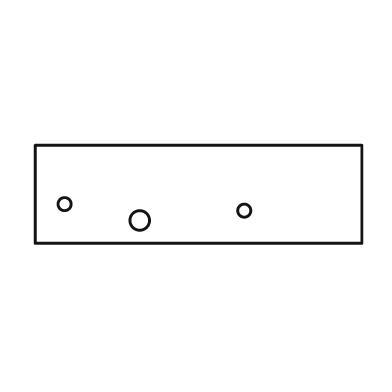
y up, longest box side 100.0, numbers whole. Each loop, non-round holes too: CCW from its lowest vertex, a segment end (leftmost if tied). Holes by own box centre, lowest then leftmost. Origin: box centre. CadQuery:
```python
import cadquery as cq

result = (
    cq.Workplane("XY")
    .moveTo(-50.0, -15.0)
    .lineTo(50.0, -15.0)
    .lineTo(50.0, 15.0)
    .lineTo(-50.0, 15.0)
    .close()
    .moveTo(-18.0, -8.0)
    .circle(3.0)
    .moveTo(14.0, -5.0)
    .circle(2.0)
    .moveTo(-41.0, -3.0)
    .circle(2.0)
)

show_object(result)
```